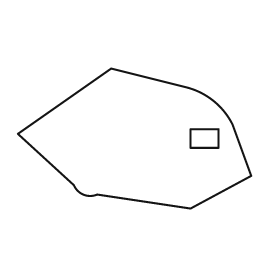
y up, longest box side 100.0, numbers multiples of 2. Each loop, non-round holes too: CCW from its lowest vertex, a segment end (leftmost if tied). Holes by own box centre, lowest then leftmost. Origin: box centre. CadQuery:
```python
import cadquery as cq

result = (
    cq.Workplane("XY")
    .moveTo(24.0, -30.0)
    .lineTo(50.0, -16.0)
    .lineTo(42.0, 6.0)
    .threePointArc((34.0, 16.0), (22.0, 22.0))
    .lineTo(-10.0, 30.0)
    .lineTo(-50.0, 2.0)
    .lineTo(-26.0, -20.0)
    .threePointArc((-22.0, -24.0), (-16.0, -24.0))
    .close()
    .moveTo(24.0, -4.0)
    .lineTo(36.0, -4.0)
    .lineTo(36.0, 4.0)
    .lineTo(24.0, 4.0)
    .close()
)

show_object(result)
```